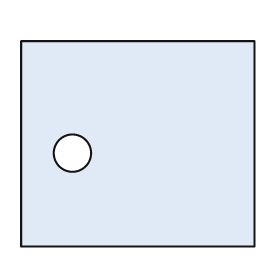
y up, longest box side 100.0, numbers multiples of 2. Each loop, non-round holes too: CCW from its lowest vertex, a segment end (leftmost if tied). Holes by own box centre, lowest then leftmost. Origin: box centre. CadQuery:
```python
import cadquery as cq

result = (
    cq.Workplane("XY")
    .moveTo(-50.0, -44.0)
    .lineTo(50.0, -44.0)
    .lineTo(50.0, 44.0)
    .lineTo(-50.0, 44.0)
    .close()
    .moveTo(-28.0, -4.0)
    .circle(8.0)
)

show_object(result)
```